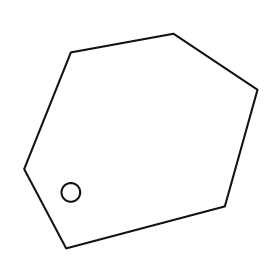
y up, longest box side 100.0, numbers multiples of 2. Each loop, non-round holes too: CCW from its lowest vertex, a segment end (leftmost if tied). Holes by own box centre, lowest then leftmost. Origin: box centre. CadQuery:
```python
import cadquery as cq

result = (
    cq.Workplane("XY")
    .moveTo(-32.0, -46.0)
    .lineTo(36.0, -28.0)
    .lineTo(50.0, 22.0)
    .lineTo(14.0, 46.0)
    .lineTo(-30.0, 38.0)
    .lineTo(-50.0, -12.0)
    .close()
    .moveTo(-30.0, -22.0)
    .circle(4.0)
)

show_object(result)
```